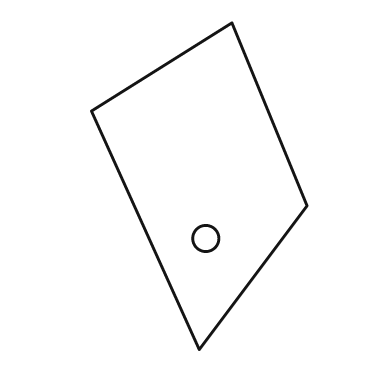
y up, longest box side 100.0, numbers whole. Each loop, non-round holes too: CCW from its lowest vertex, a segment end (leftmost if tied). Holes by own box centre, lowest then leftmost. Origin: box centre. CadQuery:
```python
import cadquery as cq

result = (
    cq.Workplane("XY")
    .moveTo(0.0, -50.0)
    .lineTo(33.0, -6.0)
    .lineTo(10.0, 50.0)
    .lineTo(-33.0, 23.0)
    .close()
    .moveTo(2.0, -16.0)
    .circle(4.0)
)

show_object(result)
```